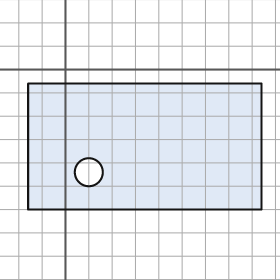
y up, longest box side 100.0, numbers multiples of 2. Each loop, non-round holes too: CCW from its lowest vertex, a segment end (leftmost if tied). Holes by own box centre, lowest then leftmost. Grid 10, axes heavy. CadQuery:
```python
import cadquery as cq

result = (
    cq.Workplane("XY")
    .moveTo(-16.0, -60.0)
    .lineTo(84.0, -60.0)
    .lineTo(84.0, -6.0)
    .lineTo(-16.0, -6.0)
    .close()
    .moveTo(10.0, -44.0)
    .circle(6.0)
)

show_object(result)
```